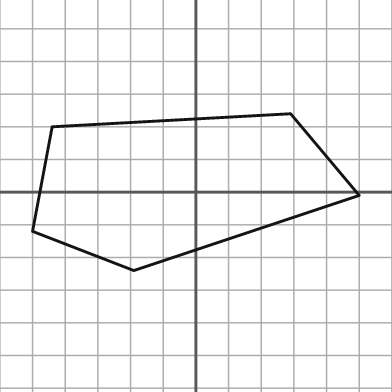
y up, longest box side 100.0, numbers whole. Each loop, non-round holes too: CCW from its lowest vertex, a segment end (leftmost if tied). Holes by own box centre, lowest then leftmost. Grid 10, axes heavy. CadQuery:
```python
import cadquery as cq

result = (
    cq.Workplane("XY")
    .moveTo(-19.0, -24.0)
    .lineTo(50.0, -1.0)
    .lineTo(29.0, 24.0)
    .lineTo(-44.0, 20.0)
    .lineTo(-50.0, -12.0)
    .close()
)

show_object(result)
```